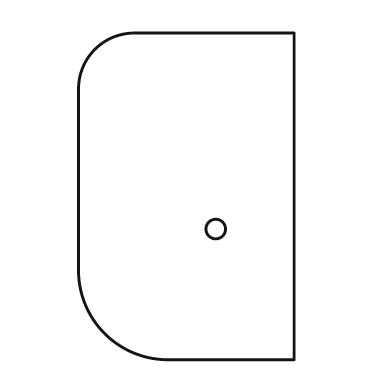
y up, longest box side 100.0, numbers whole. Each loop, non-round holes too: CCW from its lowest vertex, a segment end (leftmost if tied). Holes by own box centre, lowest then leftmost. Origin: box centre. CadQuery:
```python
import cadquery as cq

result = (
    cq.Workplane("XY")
    .moveTo(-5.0, -50.0)
    .lineTo(33.0, -50.0)
    .lineTo(33.0, 50.0)
    .lineTo(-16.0, 50.0)
    .threePointArc((-28.0, 45.0), (-33.0, 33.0))
    .lineTo(-33.0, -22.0)
    .threePointArc((-25.0, -42.0), (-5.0, -50.0))
    .close()
    .moveTo(9.0, -10.0)
    .circle(3.0)
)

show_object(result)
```